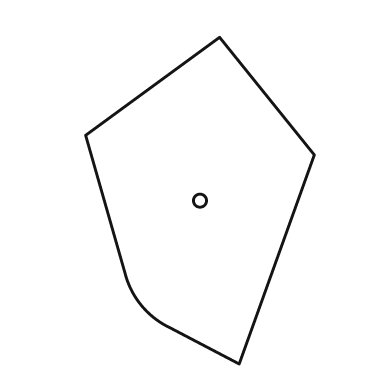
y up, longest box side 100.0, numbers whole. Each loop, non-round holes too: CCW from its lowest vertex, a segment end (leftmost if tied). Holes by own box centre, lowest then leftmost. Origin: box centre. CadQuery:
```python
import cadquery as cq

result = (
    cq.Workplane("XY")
    .moveTo(12.0, -50.0)
    .lineTo(35.0, 14.0)
    .lineTo(6.0, 50.0)
    .lineTo(-35.0, 20.0)
    .lineTo(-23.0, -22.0)
    .threePointArc((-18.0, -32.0), (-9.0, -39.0))
    .close()
    .moveTo(0.0, 0.0)
    .circle(2.0)
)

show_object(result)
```